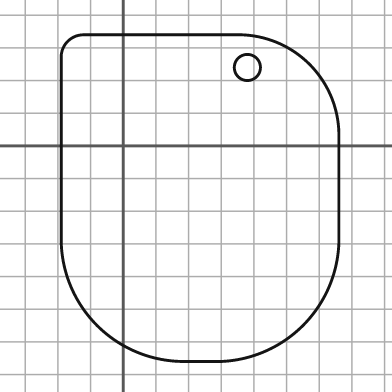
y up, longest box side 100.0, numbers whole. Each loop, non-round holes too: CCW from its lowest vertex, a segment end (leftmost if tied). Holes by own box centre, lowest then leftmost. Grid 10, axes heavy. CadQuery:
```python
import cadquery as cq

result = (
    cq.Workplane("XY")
    .moveTo(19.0, -66.0)
    .lineTo(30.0, -66.0)
    .threePointArc((55.0, -55.0), (66.0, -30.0))
    .lineTo(66.0, 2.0)
    .threePointArc((57.0, 25.0), (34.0, 34.0))
    .lineTo(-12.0, 34.0)
    .threePointArc((-17.0, 32.0), (-19.0, 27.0))
    .lineTo(-19.0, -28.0)
    .threePointArc((-8.0, -55.0), (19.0, -66.0))
    .close()
    .moveTo(38.0, 24.0)
    .circle(4.0)
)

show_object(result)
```